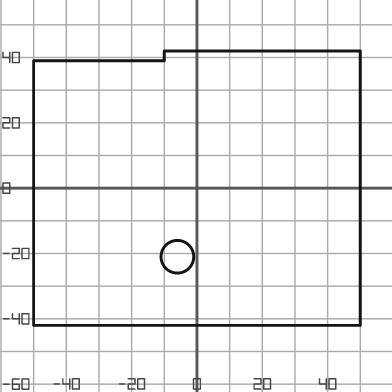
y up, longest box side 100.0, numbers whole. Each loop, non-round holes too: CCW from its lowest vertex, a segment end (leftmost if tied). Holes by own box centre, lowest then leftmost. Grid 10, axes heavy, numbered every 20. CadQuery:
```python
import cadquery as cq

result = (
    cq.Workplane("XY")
    .moveTo(-50.0, -42.0)
    .lineTo(50.0, -42.0)
    .lineTo(50.0, 42.0)
    .lineTo(-10.0, 42.0)
    .lineTo(-10.0, 39.0)
    .lineTo(-50.0, 39.0)
    .close()
    .moveTo(-6.0, -21.0)
    .circle(5.0)
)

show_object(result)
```